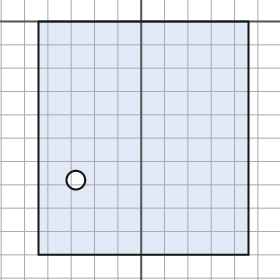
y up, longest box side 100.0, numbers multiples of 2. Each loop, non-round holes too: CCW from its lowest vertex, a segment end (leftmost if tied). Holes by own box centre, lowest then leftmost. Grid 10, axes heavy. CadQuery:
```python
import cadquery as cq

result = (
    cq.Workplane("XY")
    .moveTo(-44.0, -100.0)
    .lineTo(46.0, -100.0)
    .lineTo(46.0, 0.0)
    .lineTo(-44.0, 0.0)
    .close()
    .moveTo(-28.0, -68.0)
    .circle(4.0)
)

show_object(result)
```